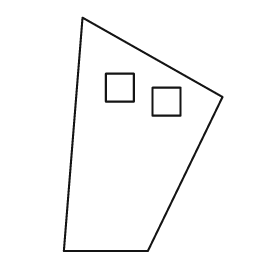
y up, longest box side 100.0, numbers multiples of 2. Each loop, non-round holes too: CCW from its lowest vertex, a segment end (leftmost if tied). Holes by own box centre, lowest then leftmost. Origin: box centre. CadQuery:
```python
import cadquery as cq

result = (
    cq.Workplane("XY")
    .moveTo(-34.0, -50.0)
    .lineTo(2.0, -50.0)
    .lineTo(34.0, 16.0)
    .lineTo(-26.0, 50.0)
    .close()
    .moveTo(4.0, 8.0)
    .lineTo(16.0, 8.0)
    .lineTo(16.0, 20.0)
    .lineTo(4.0, 20.0)
    .close()
    .moveTo(-16.0, 14.0)
    .lineTo(-4.0, 14.0)
    .lineTo(-4.0, 26.0)
    .lineTo(-16.0, 26.0)
    .close()
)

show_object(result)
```